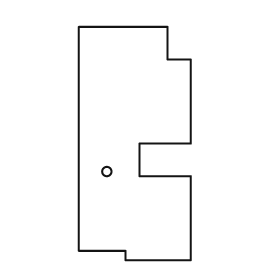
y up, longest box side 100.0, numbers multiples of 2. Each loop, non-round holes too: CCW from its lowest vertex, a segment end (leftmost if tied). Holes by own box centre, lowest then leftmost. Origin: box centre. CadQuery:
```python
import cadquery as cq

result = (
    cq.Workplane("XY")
    .moveTo(-4.0, -50.0)
    .lineTo(24.0, -50.0)
    .lineTo(24.0, -14.0)
    .lineTo(2.0, -14.0)
    .lineTo(2.0, 0.0)
    .lineTo(24.0, 0.0)
    .lineTo(24.0, 36.0)
    .lineTo(14.0, 36.0)
    .lineTo(14.0, 50.0)
    .lineTo(-24.0, 50.0)
    .lineTo(-24.0, -46.0)
    .lineTo(-4.0, -46.0)
    .close()
    .moveTo(-12.0, -12.0)
    .circle(2.0)
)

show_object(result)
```